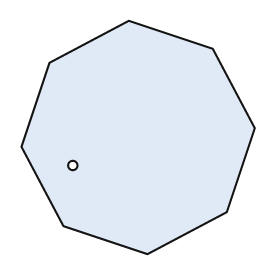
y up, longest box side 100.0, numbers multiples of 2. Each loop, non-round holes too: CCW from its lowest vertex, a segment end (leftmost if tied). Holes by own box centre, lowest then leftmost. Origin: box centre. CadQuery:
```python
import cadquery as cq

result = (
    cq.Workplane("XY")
    .moveTo(4.0, -50.0)
    .lineTo(38.0, -32.0)
    .lineTo(50.0, 4.0)
    .lineTo(32.0, 38.0)
    .lineTo(-4.0, 50.0)
    .lineTo(-38.0, 32.0)
    .lineTo(-50.0, -4.0)
    .lineTo(-32.0, -38.0)
    .close()
    .moveTo(-28.0, -12.0)
    .circle(2.0)
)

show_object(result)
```